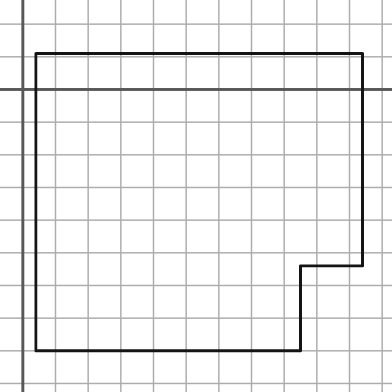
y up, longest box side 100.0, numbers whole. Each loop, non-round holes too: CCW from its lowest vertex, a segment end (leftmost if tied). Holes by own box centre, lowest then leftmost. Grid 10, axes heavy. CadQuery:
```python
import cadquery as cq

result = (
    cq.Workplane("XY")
    .moveTo(4.0, -80.0)
    .lineTo(85.0, -80.0)
    .lineTo(85.0, -54.0)
    .lineTo(104.0, -54.0)
    .lineTo(104.0, 11.0)
    .lineTo(4.0, 11.0)
    .close()
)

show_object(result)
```